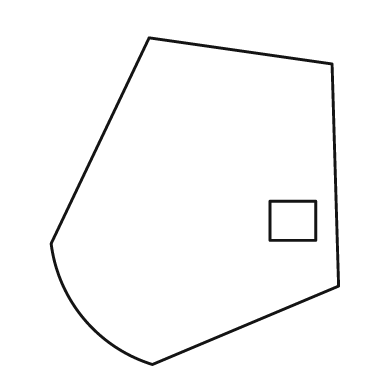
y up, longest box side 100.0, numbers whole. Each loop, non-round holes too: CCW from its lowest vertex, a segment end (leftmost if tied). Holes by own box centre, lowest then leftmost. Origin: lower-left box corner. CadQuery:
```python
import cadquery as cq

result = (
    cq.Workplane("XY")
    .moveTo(31.0, 0.0)
    .lineTo(88.0, 24.0)
    .lineTo(86.0, 92.0)
    .lineTo(30.0, 100.0)
    .lineTo(0.0, 37.0)
    .threePointArc((10.0, 14.0), (31.0, 0.0))
    .close()
    .moveTo(67.0, 38.0)
    .lineTo(81.0, 38.0)
    .lineTo(81.0, 50.0)
    .lineTo(67.0, 50.0)
    .close()
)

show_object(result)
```